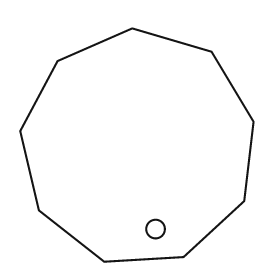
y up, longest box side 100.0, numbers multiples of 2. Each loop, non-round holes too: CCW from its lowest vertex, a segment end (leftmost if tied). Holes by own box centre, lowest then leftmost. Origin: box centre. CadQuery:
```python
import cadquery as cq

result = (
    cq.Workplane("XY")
    .moveTo(-14.0, -50.0)
    .lineTo(20.0, -48.0)
    .lineTo(46.0, -24.0)
    .lineTo(50.0, 10.0)
    .lineTo(32.0, 40.0)
    .lineTo(-2.0, 50.0)
    .lineTo(-34.0, 36.0)
    .lineTo(-50.0, 6.0)
    .lineTo(-42.0, -28.0)
    .close()
    .moveTo(8.0, -36.0)
    .circle(4.0)
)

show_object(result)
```